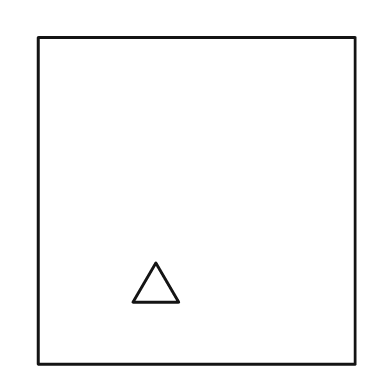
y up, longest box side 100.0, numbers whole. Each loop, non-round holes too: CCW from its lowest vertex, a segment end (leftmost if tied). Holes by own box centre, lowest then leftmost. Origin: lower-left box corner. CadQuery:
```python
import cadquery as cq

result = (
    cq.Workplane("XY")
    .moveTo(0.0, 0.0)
    .lineTo(97.0, 0.0)
    .lineTo(97.0, 100.0)
    .lineTo(0.0, 100.0)
    .close()
    .moveTo(29.0, 19.0)
    .lineTo(43.0, 19.0)
    .lineTo(36.0, 31.0)
    .close()
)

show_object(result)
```